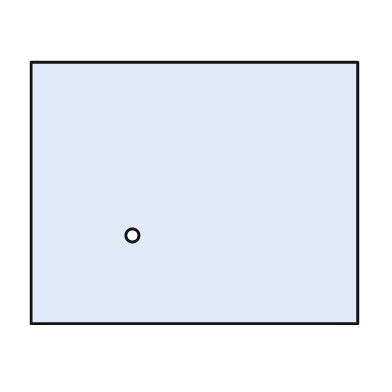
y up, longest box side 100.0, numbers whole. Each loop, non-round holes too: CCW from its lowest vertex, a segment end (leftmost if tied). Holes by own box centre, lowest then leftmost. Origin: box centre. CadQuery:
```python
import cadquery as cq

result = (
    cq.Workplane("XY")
    .moveTo(-50.0, -40.0)
    .lineTo(50.0, -40.0)
    .lineTo(50.0, 40.0)
    .lineTo(-50.0, 40.0)
    .close()
    .moveTo(-19.0, -13.0)
    .circle(2.0)
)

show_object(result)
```